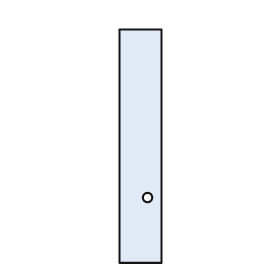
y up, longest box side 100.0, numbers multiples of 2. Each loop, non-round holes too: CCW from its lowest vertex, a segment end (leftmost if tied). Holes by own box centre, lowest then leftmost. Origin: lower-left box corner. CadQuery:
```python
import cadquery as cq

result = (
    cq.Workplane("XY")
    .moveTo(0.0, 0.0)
    .lineTo(18.0, 0.0)
    .lineTo(18.0, 100.0)
    .lineTo(0.0, 100.0)
    .close()
    .moveTo(12.0, 28.0)
    .circle(2.0)
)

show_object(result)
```